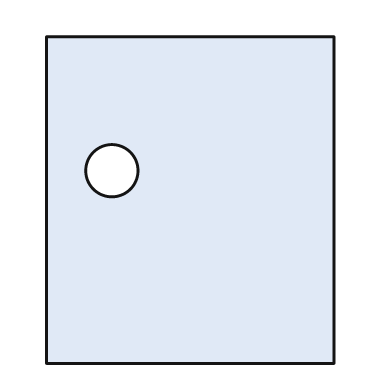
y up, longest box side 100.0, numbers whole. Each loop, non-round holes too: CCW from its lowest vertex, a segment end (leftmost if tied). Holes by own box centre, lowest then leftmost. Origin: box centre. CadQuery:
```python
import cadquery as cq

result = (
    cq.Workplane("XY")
    .moveTo(-44.0, -50.0)
    .lineTo(44.0, -50.0)
    .lineTo(44.0, 50.0)
    .lineTo(-44.0, 50.0)
    .close()
    .moveTo(-24.0, 9.0)
    .circle(8.0)
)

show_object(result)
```